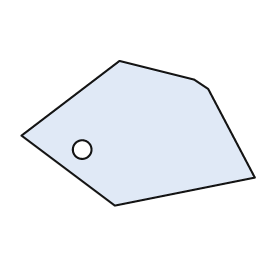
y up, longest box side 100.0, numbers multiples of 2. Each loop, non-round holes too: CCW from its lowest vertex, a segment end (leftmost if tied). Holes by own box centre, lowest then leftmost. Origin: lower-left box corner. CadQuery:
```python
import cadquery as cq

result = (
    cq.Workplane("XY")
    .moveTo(40.0, 0.0)
    .lineTo(100.0, 12.0)
    .lineTo(80.0, 50.0)
    .lineTo(74.0, 54.0)
    .lineTo(42.0, 62.0)
    .lineTo(0.0, 30.0)
    .close()
    .moveTo(26.0, 24.0)
    .circle(4.0)
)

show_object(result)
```